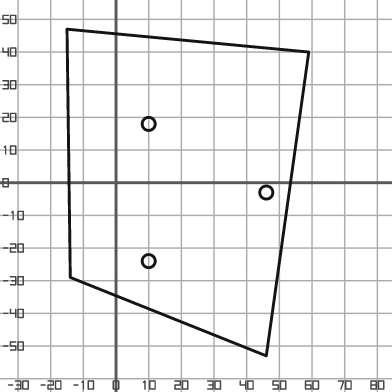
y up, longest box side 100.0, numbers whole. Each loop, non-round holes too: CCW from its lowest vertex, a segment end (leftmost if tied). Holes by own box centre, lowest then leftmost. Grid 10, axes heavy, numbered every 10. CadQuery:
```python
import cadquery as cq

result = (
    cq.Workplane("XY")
    .moveTo(46.0, -53.0)
    .lineTo(59.0, 40.0)
    .lineTo(-15.0, 47.0)
    .lineTo(-14.0, -29.0)
    .close()
    .moveTo(10.0, -24.0)
    .circle(2.0)
    .moveTo(46.0, -3.0)
    .circle(2.0)
    .moveTo(10.0, 18.0)
    .circle(2.0)
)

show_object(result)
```